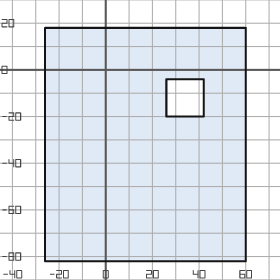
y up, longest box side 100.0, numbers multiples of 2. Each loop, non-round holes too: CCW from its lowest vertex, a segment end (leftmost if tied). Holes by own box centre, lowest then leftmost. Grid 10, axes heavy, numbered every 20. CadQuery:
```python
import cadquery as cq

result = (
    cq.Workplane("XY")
    .moveTo(-26.0, -82.0)
    .lineTo(60.0, -82.0)
    .lineTo(60.0, 18.0)
    .lineTo(-26.0, 18.0)
    .close()
    .moveTo(26.0, -20.0)
    .lineTo(42.0, -20.0)
    .lineTo(42.0, -4.0)
    .lineTo(26.0, -4.0)
    .close()
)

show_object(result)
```